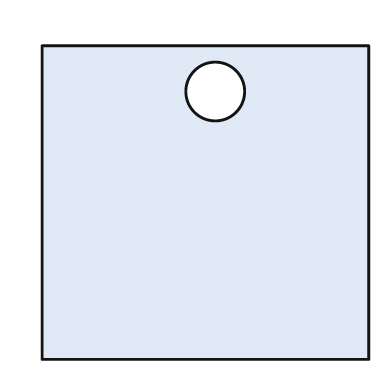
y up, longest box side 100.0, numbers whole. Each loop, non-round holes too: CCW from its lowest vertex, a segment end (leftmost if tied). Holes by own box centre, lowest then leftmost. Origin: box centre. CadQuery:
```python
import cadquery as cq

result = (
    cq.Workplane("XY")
    .moveTo(-50.0, -48.0)
    .lineTo(50.0, -48.0)
    .lineTo(50.0, 48.0)
    .lineTo(-50.0, 48.0)
    .close()
    .moveTo(3.0, 34.0)
    .circle(9.0)
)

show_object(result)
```